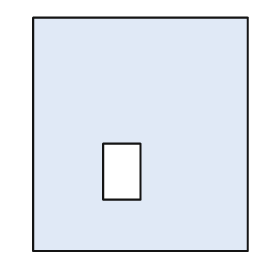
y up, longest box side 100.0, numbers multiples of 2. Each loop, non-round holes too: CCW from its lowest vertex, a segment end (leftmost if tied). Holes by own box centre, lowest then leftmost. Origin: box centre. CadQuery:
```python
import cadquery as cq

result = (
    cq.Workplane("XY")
    .moveTo(-46.0, -50.0)
    .lineTo(46.0, -50.0)
    .lineTo(46.0, 50.0)
    .lineTo(-46.0, 50.0)
    .close()
    .moveTo(-16.0, -28.0)
    .lineTo(0.0, -28.0)
    .lineTo(0.0, -4.0)
    .lineTo(-16.0, -4.0)
    .close()
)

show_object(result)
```